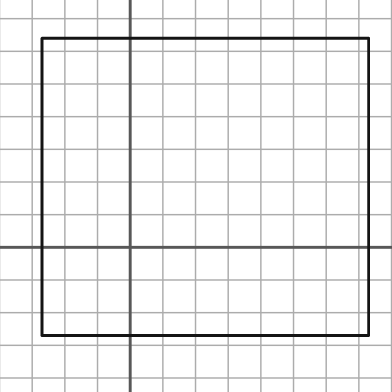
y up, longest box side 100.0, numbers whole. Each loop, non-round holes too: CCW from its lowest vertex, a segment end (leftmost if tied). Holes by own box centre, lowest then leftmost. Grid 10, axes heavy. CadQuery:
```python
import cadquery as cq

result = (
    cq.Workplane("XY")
    .moveTo(-27.0, -27.0)
    .lineTo(73.0, -27.0)
    .lineTo(73.0, 64.0)
    .lineTo(-27.0, 64.0)
    .close()
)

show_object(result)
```